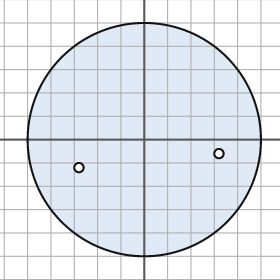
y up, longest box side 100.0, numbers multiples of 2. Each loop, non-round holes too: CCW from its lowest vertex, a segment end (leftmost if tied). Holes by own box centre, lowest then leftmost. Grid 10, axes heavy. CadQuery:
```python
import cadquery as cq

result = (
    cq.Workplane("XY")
    .moveTo(0.0, 0.0)
    .circle(50.0)
    .moveTo(-28.0, -12.0)
    .circle(2.0)
    .moveTo(32.0, -6.0)
    .circle(2.0)
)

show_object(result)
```